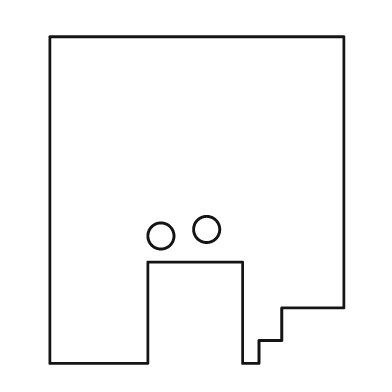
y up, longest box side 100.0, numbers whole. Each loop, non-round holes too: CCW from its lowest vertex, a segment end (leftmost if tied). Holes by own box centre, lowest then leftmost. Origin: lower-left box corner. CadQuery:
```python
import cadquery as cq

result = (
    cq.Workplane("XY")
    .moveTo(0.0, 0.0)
    .lineTo(30.0, 0.0)
    .lineTo(30.0, 31.0)
    .lineTo(59.0, 31.0)
    .lineTo(59.0, 0.0)
    .lineTo(64.0, 0.0)
    .lineTo(64.0, 7.0)
    .lineTo(71.0, 7.0)
    .lineTo(71.0, 17.0)
    .lineTo(90.0, 17.0)
    .lineTo(90.0, 100.0)
    .lineTo(0.0, 100.0)
    .close()
    .moveTo(34.0, 39.0)
    .circle(4.0)
    .moveTo(48.0, 41.0)
    .circle(4.0)
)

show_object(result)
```